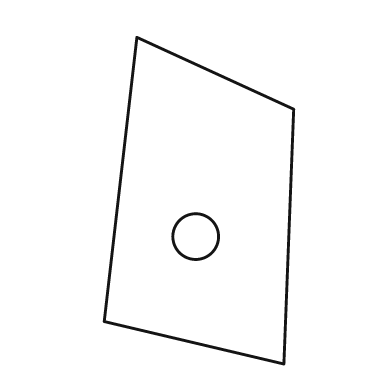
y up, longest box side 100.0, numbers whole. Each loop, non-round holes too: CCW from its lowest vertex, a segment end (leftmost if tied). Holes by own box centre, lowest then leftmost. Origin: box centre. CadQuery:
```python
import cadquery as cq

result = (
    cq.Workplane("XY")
    .moveTo(26.0, -50.0)
    .lineTo(29.0, 28.0)
    .lineTo(-19.0, 50.0)
    .lineTo(-29.0, -37.0)
    .close()
    .moveTo(-1.0, -11.0)
    .circle(7.0)
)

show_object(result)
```